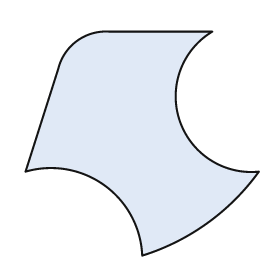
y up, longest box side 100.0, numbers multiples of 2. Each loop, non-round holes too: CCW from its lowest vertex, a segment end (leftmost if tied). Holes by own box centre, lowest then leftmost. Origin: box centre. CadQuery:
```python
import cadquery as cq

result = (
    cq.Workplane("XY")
    .moveTo(0.0, -48.0)
    .threePointArc((28.0, -34.0), (50.0, -12.0))
    .threePointArc((16.0, 10.0), (30.0, 48.0))
    .lineTo(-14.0, 48.0)
    .threePointArc((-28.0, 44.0), (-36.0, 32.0))
    .lineTo(-50.0, -12.0)
    .threePointArc((-16.0, -18.0), (0.0, -48.0))
    .close()
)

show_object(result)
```